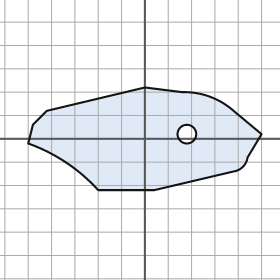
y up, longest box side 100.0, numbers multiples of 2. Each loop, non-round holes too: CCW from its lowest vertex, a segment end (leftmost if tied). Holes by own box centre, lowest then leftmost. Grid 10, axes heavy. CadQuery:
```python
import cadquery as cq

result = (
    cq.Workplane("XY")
    .moveTo(-20.0, -22.0)
    .lineTo(4.0, -22.0)
    .lineTo(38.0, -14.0)
    .threePointArc((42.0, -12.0), (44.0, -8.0))
    .lineTo(50.0, 2.0)
    .lineTo(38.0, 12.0)
    .threePointArc((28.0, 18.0), (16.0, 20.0))
    .lineTo(0.0, 22.0)
    .lineTo(-42.0, 12.0)
    .lineTo(-48.0, 6.0)
    .lineTo(-50.0, -2.0)
    .threePointArc((-34.0, -10.0), (-20.0, -22.0))
    .close()
    .moveTo(18.0, 2.0)
    .circle(4.0)
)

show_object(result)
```